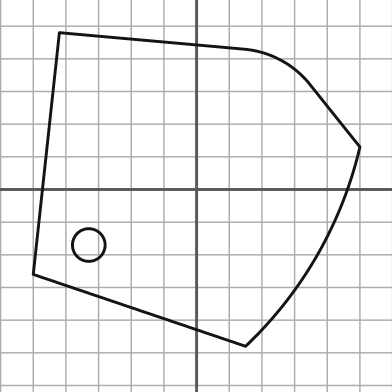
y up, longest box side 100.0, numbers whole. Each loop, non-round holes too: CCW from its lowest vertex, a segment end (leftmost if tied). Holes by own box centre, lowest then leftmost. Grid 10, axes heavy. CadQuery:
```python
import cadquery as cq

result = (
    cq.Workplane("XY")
    .moveTo(15.0, -48.0)
    .threePointArc((37.0, -20.0), (50.0, 13.0))
    .lineTo(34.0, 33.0)
    .threePointArc((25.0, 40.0), (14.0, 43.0))
    .lineTo(-42.0, 48.0)
    .lineTo(-50.0, -26.0)
    .close()
    .moveTo(-33.0, -17.0)
    .circle(5.0)
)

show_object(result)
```